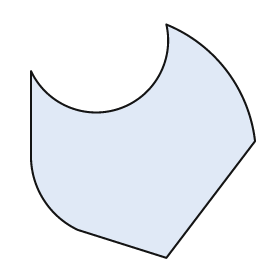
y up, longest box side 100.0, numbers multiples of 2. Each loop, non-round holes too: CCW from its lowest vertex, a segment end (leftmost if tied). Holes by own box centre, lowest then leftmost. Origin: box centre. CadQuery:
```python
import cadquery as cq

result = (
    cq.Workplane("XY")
    .moveTo(10.0, -50.0)
    .lineTo(48.0, 0.0)
    .threePointArc((36.0, 30.0), (10.0, 50.0))
    .threePointArc((-10.0, 14.0), (-48.0, 30.0))
    .lineTo(-48.0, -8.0)
    .threePointArc((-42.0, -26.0), (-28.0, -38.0))
    .close()
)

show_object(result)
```